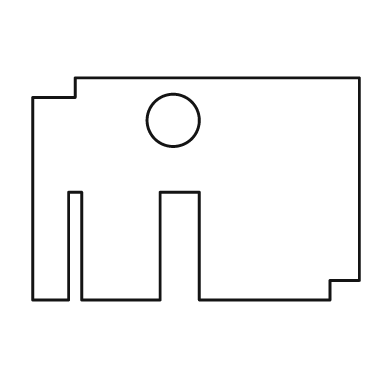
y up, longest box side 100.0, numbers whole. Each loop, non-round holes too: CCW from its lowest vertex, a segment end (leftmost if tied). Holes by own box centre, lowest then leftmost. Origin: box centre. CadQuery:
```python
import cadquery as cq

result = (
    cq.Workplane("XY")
    .moveTo(-50.0, -34.0)
    .lineTo(-39.0, -34.0)
    .lineTo(-39.0, -1.0)
    .lineTo(-35.0, -1.0)
    .lineTo(-35.0, -34.0)
    .lineTo(-11.0, -34.0)
    .lineTo(-11.0, -1.0)
    .lineTo(1.0, -1.0)
    .lineTo(1.0, -34.0)
    .lineTo(41.0, -34.0)
    .lineTo(41.0, -28.0)
    .lineTo(50.0, -28.0)
    .lineTo(50.0, 34.0)
    .lineTo(-37.0, 34.0)
    .lineTo(-37.0, 28.0)
    .lineTo(-50.0, 28.0)
    .close()
    .moveTo(-7.0, 21.0)
    .circle(8.0)
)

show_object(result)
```